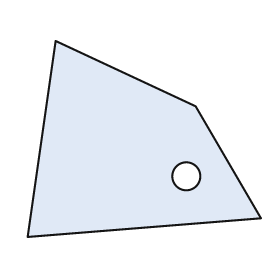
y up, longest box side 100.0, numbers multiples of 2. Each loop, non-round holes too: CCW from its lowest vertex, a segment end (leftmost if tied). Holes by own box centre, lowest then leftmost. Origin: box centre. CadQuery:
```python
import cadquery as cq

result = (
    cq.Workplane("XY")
    .moveTo(-50.0, -42.0)
    .lineTo(50.0, -34.0)
    .lineTo(22.0, 14.0)
    .lineTo(-38.0, 42.0)
    .close()
    .moveTo(18.0, -16.0)
    .circle(6.0)
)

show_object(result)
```